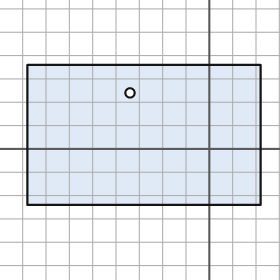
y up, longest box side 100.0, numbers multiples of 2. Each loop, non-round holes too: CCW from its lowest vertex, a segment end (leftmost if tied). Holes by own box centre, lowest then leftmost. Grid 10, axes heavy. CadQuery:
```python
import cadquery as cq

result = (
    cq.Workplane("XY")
    .moveTo(-78.0, -24.0)
    .lineTo(22.0, -24.0)
    .lineTo(22.0, 36.0)
    .lineTo(-78.0, 36.0)
    .close()
    .moveTo(-34.0, 24.0)
    .circle(2.0)
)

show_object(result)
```